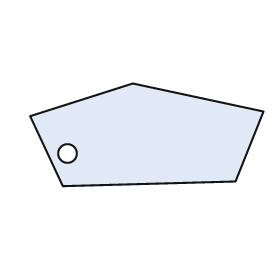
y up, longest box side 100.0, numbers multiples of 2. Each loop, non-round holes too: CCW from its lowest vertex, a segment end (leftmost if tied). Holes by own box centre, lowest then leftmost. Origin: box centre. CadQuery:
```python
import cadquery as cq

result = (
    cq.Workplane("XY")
    .moveTo(-36.0, -22.0)
    .lineTo(38.0, -20.0)
    .lineTo(50.0, 10.0)
    .lineTo(-6.0, 22.0)
    .lineTo(-50.0, 8.0)
    .close()
    .moveTo(-34.0, -8.0)
    .circle(4.0)
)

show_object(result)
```